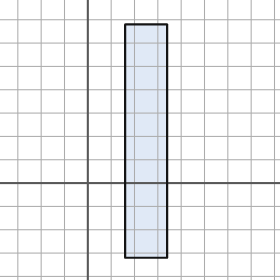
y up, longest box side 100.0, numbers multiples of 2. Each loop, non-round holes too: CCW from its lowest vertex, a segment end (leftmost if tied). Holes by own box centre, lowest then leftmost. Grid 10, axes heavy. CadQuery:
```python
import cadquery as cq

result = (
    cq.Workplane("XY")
    .moveTo(16.0, -32.0)
    .lineTo(34.0, -32.0)
    .lineTo(34.0, 68.0)
    .lineTo(16.0, 68.0)
    .close()
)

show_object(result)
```